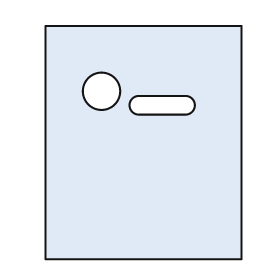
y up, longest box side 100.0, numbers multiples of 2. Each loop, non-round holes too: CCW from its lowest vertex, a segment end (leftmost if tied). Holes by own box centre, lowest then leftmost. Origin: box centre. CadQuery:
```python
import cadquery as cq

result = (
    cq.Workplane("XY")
    .moveTo(-42.0, -50.0)
    .lineTo(42.0, -50.0)
    .lineTo(42.0, 50.0)
    .lineTo(-42.0, 50.0)
    .close()
    .moveTo(-2.0, 12.0)
    .lineTo(18.0, 12.0)
    .threePointArc((22.0, 16.0), (18.0, 20.0))
    .lineTo(-2.0, 20.0)
    .threePointArc((-6.0, 16.0), (-2.0, 12.0))
    .close()
    .moveTo(-18.0, 22.0)
    .circle(8.0)
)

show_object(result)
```